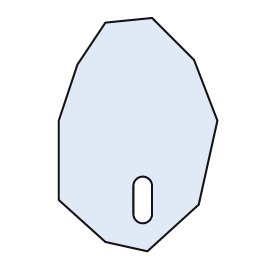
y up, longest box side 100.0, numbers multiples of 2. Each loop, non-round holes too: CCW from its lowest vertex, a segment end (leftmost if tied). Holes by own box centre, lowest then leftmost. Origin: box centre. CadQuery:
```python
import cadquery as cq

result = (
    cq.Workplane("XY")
    .moveTo(4.0, -50.0)
    .lineTo(26.0, -30.0)
    .lineTo(34.0, 6.0)
    .lineTo(24.0, 32.0)
    .lineTo(6.0, 50.0)
    .lineTo(-14.0, 48.0)
    .lineTo(-26.0, 30.0)
    .lineTo(-34.0, 6.0)
    .lineTo(-34.0, -28.0)
    .lineTo(-14.0, -46.0)
    .close()
    .moveTo(-2.0, -34.0)
    .threePointArc((2.0, -38.0), (6.0, -34.0))
    .lineTo(6.0, -22.0)
    .threePointArc((2.0, -18.0), (-2.0, -22.0))
    .close()
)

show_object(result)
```